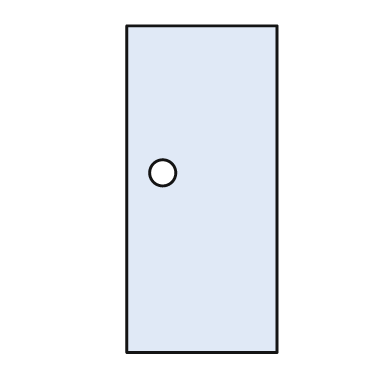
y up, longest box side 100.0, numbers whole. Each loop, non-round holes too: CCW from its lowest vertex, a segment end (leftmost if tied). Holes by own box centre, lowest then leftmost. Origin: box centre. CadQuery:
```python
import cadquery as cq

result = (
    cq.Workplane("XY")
    .moveTo(-23.0, -50.0)
    .lineTo(23.0, -50.0)
    .lineTo(23.0, 50.0)
    .lineTo(-23.0, 50.0)
    .close()
    .moveTo(-12.0, 5.0)
    .circle(4.0)
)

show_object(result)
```